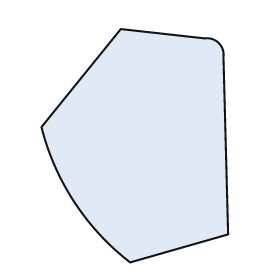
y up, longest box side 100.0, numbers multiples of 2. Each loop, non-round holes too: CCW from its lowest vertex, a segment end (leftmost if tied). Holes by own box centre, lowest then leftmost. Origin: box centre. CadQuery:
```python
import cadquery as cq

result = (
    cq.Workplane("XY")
    .moveTo(-2.0, -50.0)
    .lineTo(40.0, -38.0)
    .lineTo(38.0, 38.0)
    .threePointArc((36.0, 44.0), (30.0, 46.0))
    .lineTo(-6.0, 50.0)
    .lineTo(-40.0, 8.0)
    .threePointArc((-26.0, -24.0), (-2.0, -50.0))
    .close()
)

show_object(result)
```